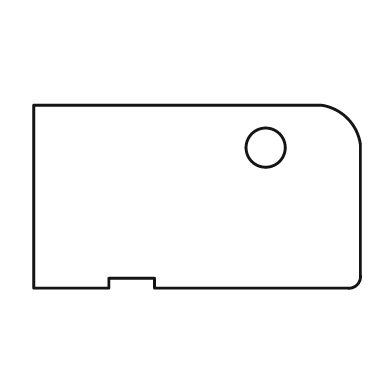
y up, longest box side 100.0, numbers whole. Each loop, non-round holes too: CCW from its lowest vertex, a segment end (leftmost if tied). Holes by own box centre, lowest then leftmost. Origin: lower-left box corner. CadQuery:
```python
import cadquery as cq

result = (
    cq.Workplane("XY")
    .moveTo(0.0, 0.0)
    .lineTo(23.0, 0.0)
    .lineTo(23.0, 3.0)
    .lineTo(37.0, 3.0)
    .lineTo(37.0, 0.0)
    .lineTo(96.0, 0.0)
    .threePointArc((99.0, 1.0), (100.0, 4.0))
    .lineTo(100.0, 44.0)
    .threePointArc((96.0, 52.0), (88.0, 56.0))
    .lineTo(0.0, 56.0)
    .close()
    .moveTo(71.0, 43.0)
    .circle(6.0)
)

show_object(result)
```